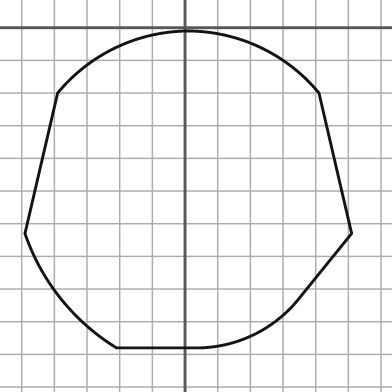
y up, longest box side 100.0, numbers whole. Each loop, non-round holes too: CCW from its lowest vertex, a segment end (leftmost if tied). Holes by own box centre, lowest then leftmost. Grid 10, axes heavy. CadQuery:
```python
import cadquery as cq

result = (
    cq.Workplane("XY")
    .moveTo(-21.0, -98.0)
    .lineTo(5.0, -98.0)
    .threePointArc((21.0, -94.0), (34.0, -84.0))
    .lineTo(51.0, -63.0)
    .lineTo(41.0, -20.0)
    .threePointArc((23.0, -6.0), (1.0, -1.0))
    .threePointArc((-21.0, -6.0), (-39.0, -20.0))
    .lineTo(-49.0, -63.0)
    .threePointArc((-38.0, -83.0), (-21.0, -98.0))
    .close()
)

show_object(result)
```